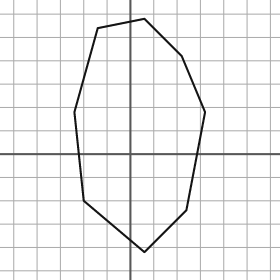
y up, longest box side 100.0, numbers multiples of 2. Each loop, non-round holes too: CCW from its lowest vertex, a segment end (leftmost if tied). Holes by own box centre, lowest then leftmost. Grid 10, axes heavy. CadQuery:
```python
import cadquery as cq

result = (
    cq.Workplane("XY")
    .moveTo(6.0, -42.0)
    .lineTo(24.0, -24.0)
    .lineTo(32.0, 18.0)
    .lineTo(22.0, 42.0)
    .lineTo(6.0, 58.0)
    .lineTo(-14.0, 54.0)
    .lineTo(-24.0, 18.0)
    .lineTo(-20.0, -20.0)
    .close()
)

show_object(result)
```